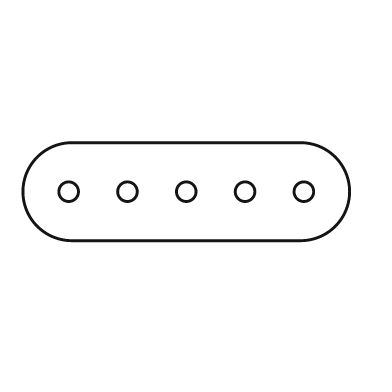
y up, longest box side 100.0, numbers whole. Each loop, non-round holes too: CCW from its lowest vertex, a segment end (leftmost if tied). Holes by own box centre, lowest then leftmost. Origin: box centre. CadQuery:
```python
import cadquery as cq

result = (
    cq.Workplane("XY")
    .moveTo(-35.0, -15.0)
    .lineTo(35.0, -15.0)
    .threePointArc((50.0, 0.0), (35.0, 15.0))
    .lineTo(-35.0, 15.0)
    .threePointArc((-50.0, 0.0), (-35.0, -15.0))
    .close()
    .moveTo(-36.0, 0.0)
    .circle(3.0)
    .moveTo(-18.0, 0.0)
    .circle(3.0)
    .moveTo(0.0, 0.0)
    .circle(3.0)
    .moveTo(18.0, 0.0)
    .circle(3.0)
    .moveTo(36.0, 0.0)
    .circle(3.0)
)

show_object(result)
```